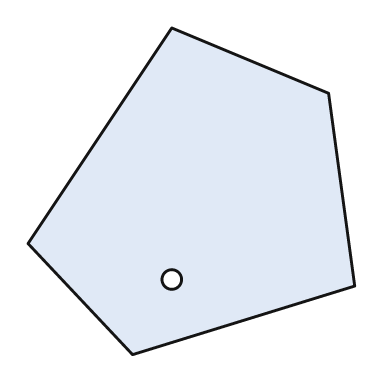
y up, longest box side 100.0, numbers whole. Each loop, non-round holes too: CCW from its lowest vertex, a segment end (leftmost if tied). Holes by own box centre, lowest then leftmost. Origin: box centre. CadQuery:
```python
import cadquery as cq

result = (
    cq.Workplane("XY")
    .moveTo(-18.0, -50.0)
    .lineTo(50.0, -29.0)
    .lineTo(42.0, 30.0)
    .lineTo(-6.0, 50.0)
    .lineTo(-50.0, -16.0)
    .close()
    .moveTo(-6.0, -27.0)
    .circle(3.0)
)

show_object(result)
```